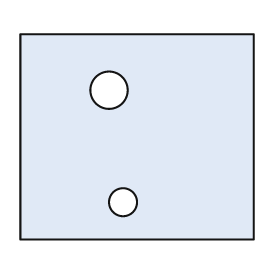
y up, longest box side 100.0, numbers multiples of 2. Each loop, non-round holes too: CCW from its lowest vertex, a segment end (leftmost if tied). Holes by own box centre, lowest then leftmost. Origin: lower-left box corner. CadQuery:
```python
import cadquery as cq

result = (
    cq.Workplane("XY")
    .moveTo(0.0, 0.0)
    .lineTo(100.0, 0.0)
    .lineTo(100.0, 88.0)
    .lineTo(0.0, 88.0)
    .close()
    .moveTo(44.0, 16.0)
    .circle(6.0)
    .moveTo(38.0, 64.0)
    .circle(8.0)
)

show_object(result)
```